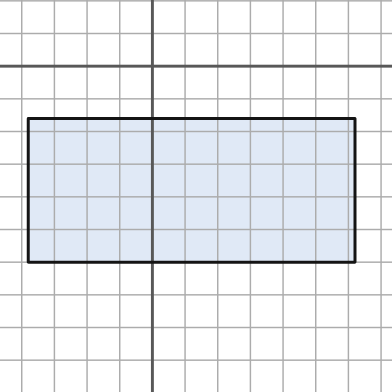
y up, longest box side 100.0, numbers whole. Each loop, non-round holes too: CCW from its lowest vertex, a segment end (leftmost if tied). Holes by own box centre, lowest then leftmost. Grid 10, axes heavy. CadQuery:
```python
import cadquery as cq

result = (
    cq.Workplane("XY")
    .moveTo(-38.0, -60.0)
    .lineTo(62.0, -60.0)
    .lineTo(62.0, -16.0)
    .lineTo(-38.0, -16.0)
    .close()
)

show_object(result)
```